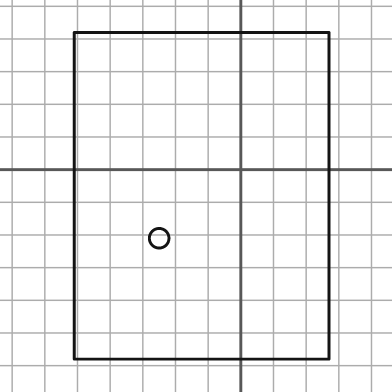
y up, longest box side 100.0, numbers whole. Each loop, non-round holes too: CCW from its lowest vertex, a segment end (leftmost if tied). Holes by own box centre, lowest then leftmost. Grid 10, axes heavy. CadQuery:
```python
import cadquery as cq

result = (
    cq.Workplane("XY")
    .moveTo(-51.0, -58.0)
    .lineTo(27.0, -58.0)
    .lineTo(27.0, 42.0)
    .lineTo(-51.0, 42.0)
    .close()
    .moveTo(-25.0, -21.0)
    .circle(3.0)
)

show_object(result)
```